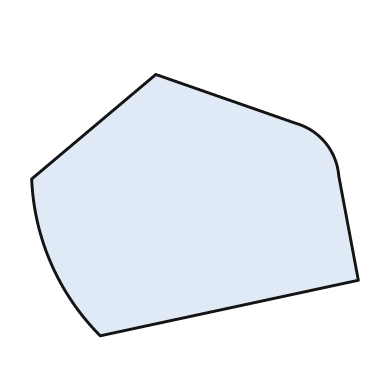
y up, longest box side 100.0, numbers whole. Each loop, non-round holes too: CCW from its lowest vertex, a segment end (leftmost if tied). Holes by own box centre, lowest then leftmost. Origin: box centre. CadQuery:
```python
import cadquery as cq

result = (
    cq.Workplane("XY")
    .moveTo(-29.0, -40.0)
    .lineTo(50.0, -23.0)
    .lineTo(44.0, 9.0)
    .threePointArc((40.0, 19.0), (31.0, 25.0))
    .lineTo(-12.0, 40.0)
    .lineTo(-50.0, 8.0)
    .threePointArc((-44.0, -18.0), (-29.0, -40.0))
    .close()
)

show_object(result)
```